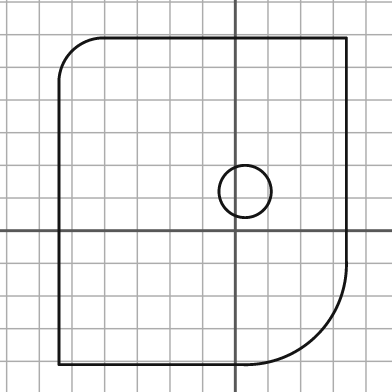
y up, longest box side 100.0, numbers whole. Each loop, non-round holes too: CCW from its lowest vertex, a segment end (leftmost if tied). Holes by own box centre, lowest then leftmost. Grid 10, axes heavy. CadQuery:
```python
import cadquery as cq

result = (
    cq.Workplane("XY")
    .moveTo(-54.0, -41.0)
    .lineTo(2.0, -41.0)
    .threePointArc((25.0, -32.0), (34.0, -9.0))
    .lineTo(34.0, 59.0)
    .lineTo(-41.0, 59.0)
    .threePointArc((-50.0, 55.0), (-54.0, 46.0))
    .close()
    .moveTo(3.0, 12.0)
    .circle(8.0)
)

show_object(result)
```